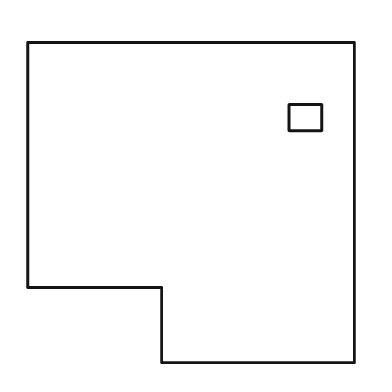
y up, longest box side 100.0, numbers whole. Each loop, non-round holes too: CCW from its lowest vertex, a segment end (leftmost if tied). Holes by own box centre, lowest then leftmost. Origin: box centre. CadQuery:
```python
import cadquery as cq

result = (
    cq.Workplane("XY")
    .moveTo(-9.0, -49.0)
    .lineTo(50.0, -49.0)
    .lineTo(50.0, 49.0)
    .lineTo(-50.0, 49.0)
    .lineTo(-50.0, -26.0)
    .lineTo(-9.0, -26.0)
    .close()
    .moveTo(30.0, 22.0)
    .lineTo(40.0, 22.0)
    .lineTo(40.0, 30.0)
    .lineTo(30.0, 30.0)
    .close()
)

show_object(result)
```